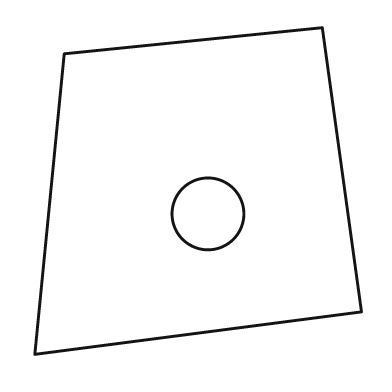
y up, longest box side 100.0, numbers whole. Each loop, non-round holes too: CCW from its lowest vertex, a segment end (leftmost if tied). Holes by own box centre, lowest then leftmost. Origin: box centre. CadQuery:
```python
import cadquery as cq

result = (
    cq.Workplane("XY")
    .moveTo(-50.0, -50.0)
    .lineTo(50.0, -37.0)
    .lineTo(38.0, 50.0)
    .lineTo(-41.0, 42.0)
    .close()
    .moveTo(3.0, -7.0)
    .circle(11.0)
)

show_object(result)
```